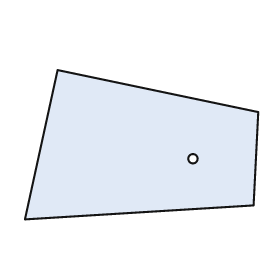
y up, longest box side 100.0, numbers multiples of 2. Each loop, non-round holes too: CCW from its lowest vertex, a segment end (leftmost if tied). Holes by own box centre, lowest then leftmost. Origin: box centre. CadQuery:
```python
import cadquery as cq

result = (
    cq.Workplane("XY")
    .moveTo(-50.0, -32.0)
    .lineTo(48.0, -26.0)
    .lineTo(50.0, 14.0)
    .lineTo(-36.0, 32.0)
    .close()
    .moveTo(22.0, -6.0)
    .circle(2.0)
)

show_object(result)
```